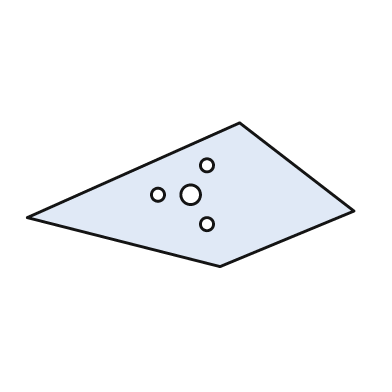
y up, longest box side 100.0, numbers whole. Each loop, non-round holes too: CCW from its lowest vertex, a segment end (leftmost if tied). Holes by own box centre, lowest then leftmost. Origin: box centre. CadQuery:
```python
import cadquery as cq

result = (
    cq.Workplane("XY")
    .moveTo(9.0, -22.0)
    .lineTo(50.0, -5.0)
    .lineTo(15.0, 22.0)
    .lineTo(-50.0, -7.0)
    .close()
    .moveTo(5.0, -9.0)
    .circle(2.0)
    .moveTo(-10.0, 0.0)
    .circle(2.0)
    .moveTo(0.0, 0.0)
    .circle(3.0)
    .moveTo(5.0, 9.0)
    .circle(2.0)
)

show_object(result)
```